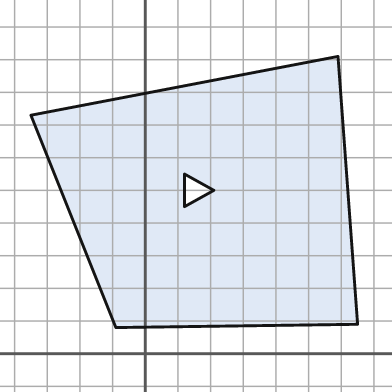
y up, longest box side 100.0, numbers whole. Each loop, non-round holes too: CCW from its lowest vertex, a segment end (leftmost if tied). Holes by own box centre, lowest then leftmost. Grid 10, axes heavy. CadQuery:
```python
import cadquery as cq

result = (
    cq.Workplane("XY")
    .moveTo(-9.0, 8.0)
    .lineTo(65.0, 9.0)
    .lineTo(59.0, 91.0)
    .lineTo(-35.0, 73.0)
    .close()
    .moveTo(12.0, 45.0)
    .lineTo(21.0, 50.0)
    .lineTo(12.0, 55.0)
    .close()
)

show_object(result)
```